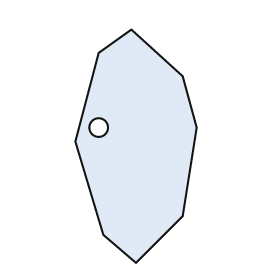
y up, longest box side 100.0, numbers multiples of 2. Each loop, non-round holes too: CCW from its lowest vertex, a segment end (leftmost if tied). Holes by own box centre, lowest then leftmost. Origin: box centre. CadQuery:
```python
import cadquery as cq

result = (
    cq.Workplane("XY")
    .moveTo(0.0, -50.0)
    .lineTo(20.0, -30.0)
    .lineTo(26.0, 8.0)
    .lineTo(20.0, 30.0)
    .lineTo(-2.0, 50.0)
    .lineTo(-16.0, 40.0)
    .lineTo(-26.0, 2.0)
    .lineTo(-14.0, -38.0)
    .close()
    .moveTo(-16.0, 8.0)
    .circle(4.0)
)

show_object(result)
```